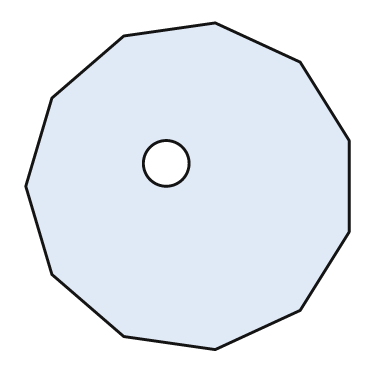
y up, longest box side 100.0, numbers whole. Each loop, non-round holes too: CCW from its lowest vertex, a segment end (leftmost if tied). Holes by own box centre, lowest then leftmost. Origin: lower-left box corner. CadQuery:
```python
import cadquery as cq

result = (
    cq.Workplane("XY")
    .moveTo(58.0, 0.0)
    .lineTo(84.0, 12.0)
    .lineTo(99.0, 36.0)
    .lineTo(99.0, 64.0)
    .lineTo(84.0, 88.0)
    .lineTo(58.0, 100.0)
    .lineTo(30.0, 96.0)
    .lineTo(8.0, 77.0)
    .lineTo(0.0, 50.0)
    .lineTo(8.0, 23.0)
    .lineTo(30.0, 4.0)
    .close()
    .moveTo(43.0, 57.0)
    .circle(7.0)
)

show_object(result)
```